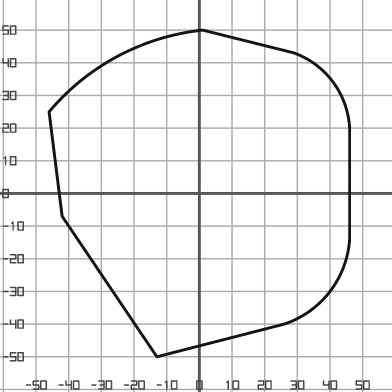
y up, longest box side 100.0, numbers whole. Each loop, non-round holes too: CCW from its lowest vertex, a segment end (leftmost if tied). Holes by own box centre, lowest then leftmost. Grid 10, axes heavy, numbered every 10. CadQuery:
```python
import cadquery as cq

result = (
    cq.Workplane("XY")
    .moveTo(-13.0, -50.0)
    .lineTo(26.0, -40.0)
    .threePointArc((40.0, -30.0), (46.0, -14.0))
    .lineTo(46.0, 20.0)
    .threePointArc((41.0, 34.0), (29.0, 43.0))
    .lineTo(1.0, 50.0)
    .threePointArc((-25.0, 42.0), (-46.0, 25.0))
    .lineTo(-42.0, -7.0)
    .close()
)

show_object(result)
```